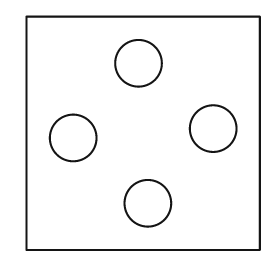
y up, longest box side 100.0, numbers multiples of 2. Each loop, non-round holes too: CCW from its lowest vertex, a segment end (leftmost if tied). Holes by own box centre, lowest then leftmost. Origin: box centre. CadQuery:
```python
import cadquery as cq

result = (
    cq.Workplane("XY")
    .moveTo(-50.0, -50.0)
    .lineTo(50.0, -50.0)
    .lineTo(50.0, 50.0)
    .lineTo(-50.0, 50.0)
    .close()
    .moveTo(2.0, -30.0)
    .circle(10.0)
    .moveTo(-30.0, -2.0)
    .circle(10.0)
    .moveTo(30.0, 2.0)
    .circle(10.0)
    .moveTo(-2.0, 30.0)
    .circle(10.0)
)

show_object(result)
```